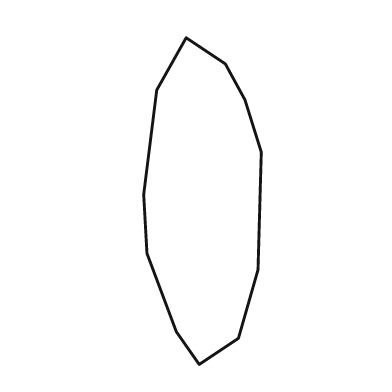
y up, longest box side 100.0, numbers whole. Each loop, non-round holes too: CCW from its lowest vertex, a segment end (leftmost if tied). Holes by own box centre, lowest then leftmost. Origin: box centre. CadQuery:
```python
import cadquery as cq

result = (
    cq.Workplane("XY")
    .moveTo(-1.0, -50.0)
    .lineTo(11.0, -42.0)
    .lineTo(17.0, -21.0)
    .lineTo(18.0, 15.0)
    .lineTo(13.0, 31.0)
    .lineTo(7.0, 42.0)
    .lineTo(-5.0, 50.0)
    .lineTo(-14.0, 34.0)
    .lineTo(-18.0, 2.0)
    .lineTo(-17.0, -16.0)
    .lineTo(-8.0, -40.0)
    .close()
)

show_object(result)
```